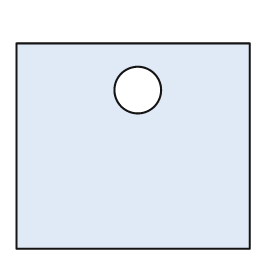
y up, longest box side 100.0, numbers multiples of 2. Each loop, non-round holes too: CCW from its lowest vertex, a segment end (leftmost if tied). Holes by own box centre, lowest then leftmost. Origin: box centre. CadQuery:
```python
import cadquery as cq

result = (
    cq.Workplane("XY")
    .moveTo(-50.0, -44.0)
    .lineTo(50.0, -44.0)
    .lineTo(50.0, 44.0)
    .lineTo(-50.0, 44.0)
    .close()
    .moveTo(2.0, 24.0)
    .circle(10.0)
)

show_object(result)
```